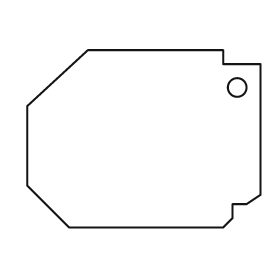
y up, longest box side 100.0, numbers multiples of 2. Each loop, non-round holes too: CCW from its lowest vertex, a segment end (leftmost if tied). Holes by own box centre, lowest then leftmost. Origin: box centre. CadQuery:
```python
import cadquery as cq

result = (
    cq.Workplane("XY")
    .moveTo(-32.0, -38.0)
    .lineTo(34.0, -38.0)
    .lineTo(38.0, -34.0)
    .lineTo(38.0, -28.0)
    .lineTo(44.0, -28.0)
    .lineTo(50.0, -24.0)
    .lineTo(50.0, 32.0)
    .lineTo(34.0, 32.0)
    .lineTo(34.0, 38.0)
    .lineTo(-24.0, 38.0)
    .lineTo(-50.0, 14.0)
    .lineTo(-50.0, -20.0)
    .close()
    .moveTo(40.0, 22.0)
    .circle(4.0)
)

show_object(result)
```